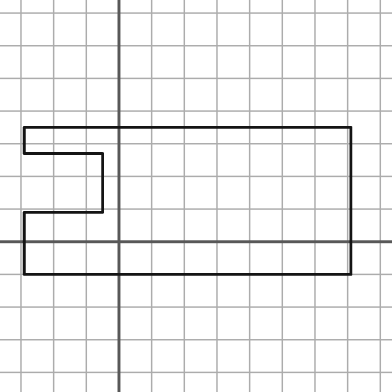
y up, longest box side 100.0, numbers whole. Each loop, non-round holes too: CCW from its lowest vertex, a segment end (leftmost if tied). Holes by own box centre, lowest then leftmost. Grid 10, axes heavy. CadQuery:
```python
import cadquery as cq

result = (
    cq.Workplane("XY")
    .moveTo(-29.0, -10.0)
    .lineTo(71.0, -10.0)
    .lineTo(71.0, 35.0)
    .lineTo(-29.0, 35.0)
    .lineTo(-29.0, 27.0)
    .lineTo(-5.0, 27.0)
    .lineTo(-5.0, 9.0)
    .lineTo(-29.0, 9.0)
    .close()
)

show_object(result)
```